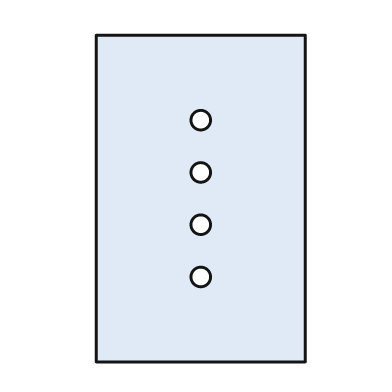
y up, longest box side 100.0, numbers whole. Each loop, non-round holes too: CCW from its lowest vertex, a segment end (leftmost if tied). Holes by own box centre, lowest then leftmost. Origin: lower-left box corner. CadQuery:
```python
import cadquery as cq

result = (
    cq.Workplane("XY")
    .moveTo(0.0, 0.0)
    .lineTo(64.0, 0.0)
    .lineTo(64.0, 100.0)
    .lineTo(0.0, 100.0)
    .close()
    .moveTo(32.0, 26.0)
    .circle(3.0)
    .moveTo(32.0, 42.0)
    .circle(3.0)
    .moveTo(32.0, 58.0)
    .circle(3.0)
    .moveTo(32.0, 74.0)
    .circle(3.0)
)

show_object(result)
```